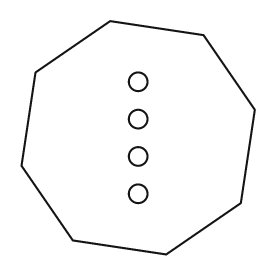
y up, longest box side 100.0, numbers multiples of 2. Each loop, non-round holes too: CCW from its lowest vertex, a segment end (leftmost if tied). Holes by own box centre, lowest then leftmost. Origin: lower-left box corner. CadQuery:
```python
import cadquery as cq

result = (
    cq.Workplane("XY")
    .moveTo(62.0, 0.0)
    .lineTo(94.0, 22.0)
    .lineTo(100.0, 62.0)
    .lineTo(78.0, 94.0)
    .lineTo(38.0, 100.0)
    .lineTo(6.0, 78.0)
    .lineTo(0.0, 38.0)
    .lineTo(22.0, 6.0)
    .close()
    .moveTo(50.0, 26.0)
    .circle(4.0)
    .moveTo(50.0, 42.0)
    .circle(4.0)
    .moveTo(50.0, 58.0)
    .circle(4.0)
    .moveTo(50.0, 74.0)
    .circle(4.0)
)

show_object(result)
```